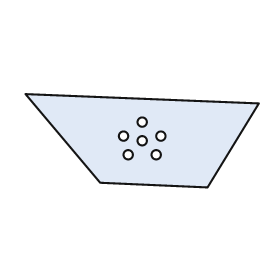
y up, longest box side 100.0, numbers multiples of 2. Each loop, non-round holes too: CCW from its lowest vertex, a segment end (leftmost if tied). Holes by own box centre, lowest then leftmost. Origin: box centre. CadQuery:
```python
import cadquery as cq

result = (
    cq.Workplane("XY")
    .moveTo(28.0, -20.0)
    .lineTo(50.0, 16.0)
    .lineTo(-50.0, 20.0)
    .lineTo(-18.0, -18.0)
    .close()
    .moveTo(-6.0, -6.0)
    .circle(2.0)
    .moveTo(6.0, -6.0)
    .circle(2.0)
    .moveTo(0.0, 0.0)
    .circle(2.0)
    .moveTo(-8.0, 2.0)
    .circle(2.0)
    .moveTo(8.0, 2.0)
    .circle(2.0)
    .moveTo(0.0, 8.0)
    .circle(2.0)
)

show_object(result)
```